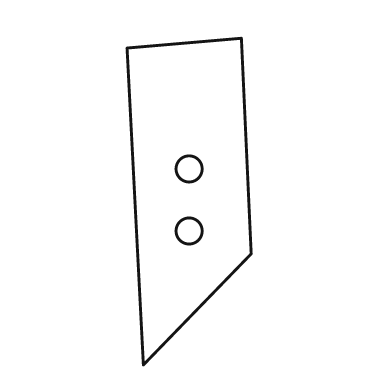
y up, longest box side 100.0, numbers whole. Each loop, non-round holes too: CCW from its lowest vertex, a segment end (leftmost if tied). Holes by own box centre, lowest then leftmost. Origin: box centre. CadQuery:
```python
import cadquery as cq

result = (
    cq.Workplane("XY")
    .moveTo(-14.0, -50.0)
    .lineTo(19.0, -16.0)
    .lineTo(16.0, 50.0)
    .lineTo(-19.0, 47.0)
    .close()
    .moveTo(0.0, -9.0)
    .circle(4.0)
    .moveTo(0.0, 10.0)
    .circle(4.0)
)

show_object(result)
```